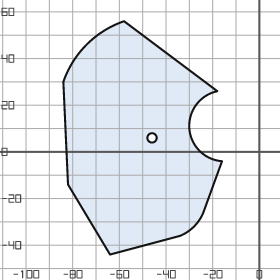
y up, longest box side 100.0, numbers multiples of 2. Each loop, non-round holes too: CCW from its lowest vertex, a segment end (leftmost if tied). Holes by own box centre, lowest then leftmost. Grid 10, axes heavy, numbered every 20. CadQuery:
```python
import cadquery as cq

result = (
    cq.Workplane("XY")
    .moveTo(-64.0, -44.0)
    .lineTo(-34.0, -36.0)
    .threePointArc((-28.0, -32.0), (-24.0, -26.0))
    .lineTo(-16.0, -4.0)
    .threePointArc((-30.0, 10.0), (-18.0, 26.0))
    .lineTo(-58.0, 56.0)
    .threePointArc((-74.0, 46.0), (-84.0, 30.0))
    .lineTo(-82.0, -14.0)
    .close()
    .moveTo(-46.0, 6.0)
    .circle(2.0)
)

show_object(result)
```